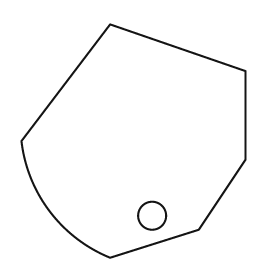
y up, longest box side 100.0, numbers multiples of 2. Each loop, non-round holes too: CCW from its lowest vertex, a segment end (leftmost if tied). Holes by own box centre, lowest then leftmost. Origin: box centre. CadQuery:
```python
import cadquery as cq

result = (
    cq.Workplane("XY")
    .moveTo(-10.0, -50.0)
    .lineTo(28.0, -38.0)
    .lineTo(48.0, -8.0)
    .lineTo(48.0, 30.0)
    .lineTo(-10.0, 50.0)
    .lineTo(-48.0, 0.0)
    .threePointArc((-36.0, -30.0), (-10.0, -50.0))
    .close()
    .moveTo(8.0, -32.0)
    .circle(6.0)
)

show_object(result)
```